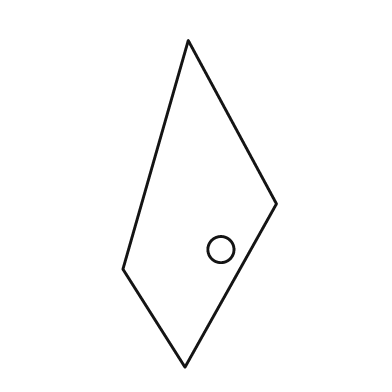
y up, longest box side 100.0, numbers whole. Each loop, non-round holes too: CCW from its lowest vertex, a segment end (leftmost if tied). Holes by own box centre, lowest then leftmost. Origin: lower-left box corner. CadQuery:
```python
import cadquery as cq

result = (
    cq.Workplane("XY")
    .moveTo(19.0, 0.0)
    .lineTo(47.0, 50.0)
    .lineTo(20.0, 100.0)
    .lineTo(0.0, 30.0)
    .close()
    .moveTo(30.0, 36.0)
    .circle(4.0)
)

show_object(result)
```